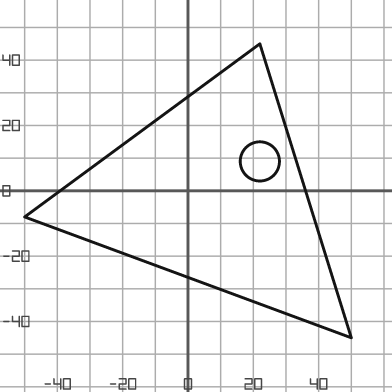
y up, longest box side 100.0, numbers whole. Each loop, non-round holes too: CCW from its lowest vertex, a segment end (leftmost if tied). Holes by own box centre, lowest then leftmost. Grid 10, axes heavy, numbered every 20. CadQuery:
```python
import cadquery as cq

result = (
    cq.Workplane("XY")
    .moveTo(50.0, -45.0)
    .lineTo(22.0, 45.0)
    .lineTo(-50.0, -8.0)
    .close()
    .moveTo(22.0, 9.0)
    .circle(6.0)
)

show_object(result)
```